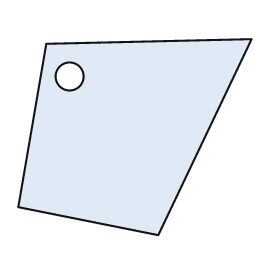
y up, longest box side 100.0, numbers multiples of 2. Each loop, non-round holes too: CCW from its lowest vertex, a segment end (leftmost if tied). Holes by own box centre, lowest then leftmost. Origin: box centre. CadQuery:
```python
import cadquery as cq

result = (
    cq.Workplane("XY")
    .moveTo(10.0, -42.0)
    .lineTo(50.0, 42.0)
    .lineTo(-38.0, 40.0)
    .lineTo(-50.0, -30.0)
    .close()
    .moveTo(-28.0, 26.0)
    .circle(6.0)
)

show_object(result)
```